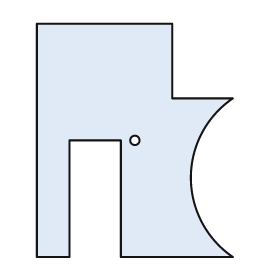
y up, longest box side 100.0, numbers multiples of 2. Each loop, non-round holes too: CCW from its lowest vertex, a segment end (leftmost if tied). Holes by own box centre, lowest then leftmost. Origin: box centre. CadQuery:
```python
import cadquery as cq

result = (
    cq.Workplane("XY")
    .moveTo(-42.0, -50.0)
    .lineTo(-28.0, -50.0)
    .lineTo(-28.0, 0.0)
    .lineTo(-6.0, 0.0)
    .lineTo(-6.0, -50.0)
    .lineTo(42.0, -50.0)
    .threePointArc((24.0, -16.0), (42.0, 18.0))
    .lineTo(16.0, 18.0)
    .lineTo(16.0, 50.0)
    .lineTo(-42.0, 50.0)
    .close()
    .moveTo(0.0, 0.0)
    .circle(2.0)
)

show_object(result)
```